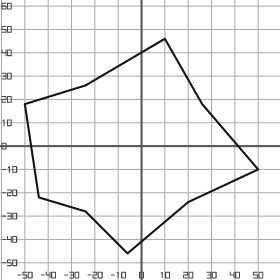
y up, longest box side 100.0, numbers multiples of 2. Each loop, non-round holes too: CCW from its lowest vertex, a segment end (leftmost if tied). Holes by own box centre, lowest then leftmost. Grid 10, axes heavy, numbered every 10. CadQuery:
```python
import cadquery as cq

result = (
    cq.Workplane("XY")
    .moveTo(-6.0, -46.0)
    .lineTo(20.0, -24.0)
    .lineTo(50.0, -10.0)
    .lineTo(26.0, 18.0)
    .lineTo(10.0, 46.0)
    .lineTo(-24.0, 26.0)
    .lineTo(-50.0, 18.0)
    .lineTo(-44.0, -22.0)
    .lineTo(-24.0, -28.0)
    .close()
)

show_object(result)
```